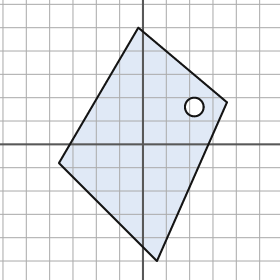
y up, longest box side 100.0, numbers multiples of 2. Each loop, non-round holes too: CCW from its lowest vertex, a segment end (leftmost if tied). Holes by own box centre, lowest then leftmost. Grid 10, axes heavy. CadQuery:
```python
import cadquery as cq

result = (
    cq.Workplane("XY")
    .moveTo(6.0, -50.0)
    .lineTo(36.0, 18.0)
    .lineTo(-2.0, 50.0)
    .lineTo(-36.0, -8.0)
    .close()
    .moveTo(22.0, 16.0)
    .circle(4.0)
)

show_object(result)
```